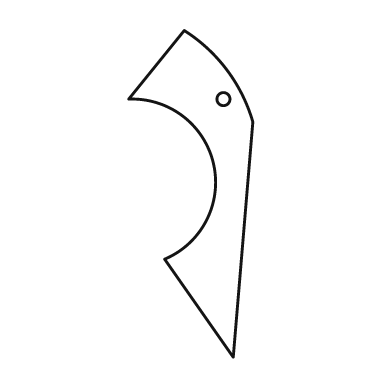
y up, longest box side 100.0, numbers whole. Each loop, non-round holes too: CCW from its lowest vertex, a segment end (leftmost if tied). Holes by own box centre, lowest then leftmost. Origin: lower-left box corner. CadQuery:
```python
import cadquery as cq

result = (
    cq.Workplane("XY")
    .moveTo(32.0, 0.0)
    .lineTo(38.0, 72.0)
    .threePointArc((30.0, 88.0), (17.0, 100.0))
    .lineTo(0.0, 79.0)
    .threePointArc((26.0, 59.0), (11.0, 30.0))
    .close()
    .moveTo(29.0, 79.0)
    .circle(2.0)
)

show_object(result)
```